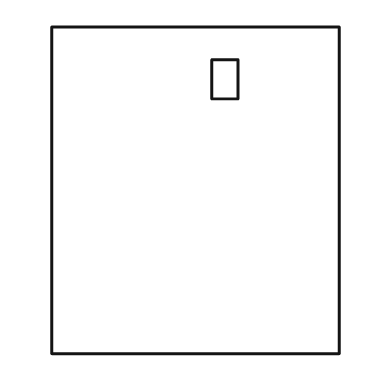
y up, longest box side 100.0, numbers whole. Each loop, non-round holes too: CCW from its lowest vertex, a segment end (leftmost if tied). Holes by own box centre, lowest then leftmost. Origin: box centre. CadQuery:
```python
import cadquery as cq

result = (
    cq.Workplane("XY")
    .moveTo(-44.0, -50.0)
    .lineTo(44.0, -50.0)
    .lineTo(44.0, 50.0)
    .lineTo(-44.0, 50.0)
    .close()
    .moveTo(5.0, 28.0)
    .lineTo(13.0, 28.0)
    .lineTo(13.0, 40.0)
    .lineTo(5.0, 40.0)
    .close()
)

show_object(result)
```